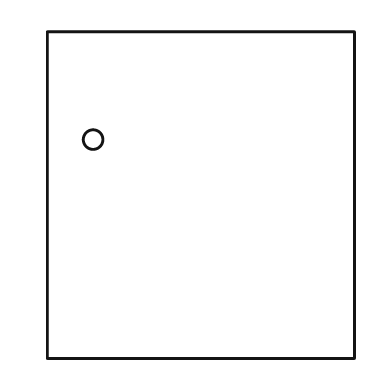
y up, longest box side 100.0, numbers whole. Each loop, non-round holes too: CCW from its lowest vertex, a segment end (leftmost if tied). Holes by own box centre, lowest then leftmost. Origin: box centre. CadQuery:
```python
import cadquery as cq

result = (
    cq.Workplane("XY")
    .moveTo(-47.0, -50.0)
    .lineTo(47.0, -50.0)
    .lineTo(47.0, 50.0)
    .lineTo(-47.0, 50.0)
    .close()
    .moveTo(-33.0, 17.0)
    .circle(3.0)
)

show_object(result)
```